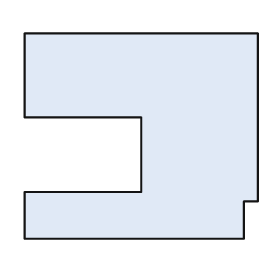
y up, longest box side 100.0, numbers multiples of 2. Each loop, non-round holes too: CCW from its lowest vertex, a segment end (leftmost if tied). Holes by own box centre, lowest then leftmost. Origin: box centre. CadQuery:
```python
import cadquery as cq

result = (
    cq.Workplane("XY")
    .moveTo(-50.0, -44.0)
    .lineTo(44.0, -44.0)
    .lineTo(44.0, -28.0)
    .lineTo(50.0, -28.0)
    .lineTo(50.0, 44.0)
    .lineTo(-50.0, 44.0)
    .lineTo(-50.0, 8.0)
    .lineTo(0.0, 8.0)
    .lineTo(0.0, -24.0)
    .lineTo(-50.0, -24.0)
    .close()
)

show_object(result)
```